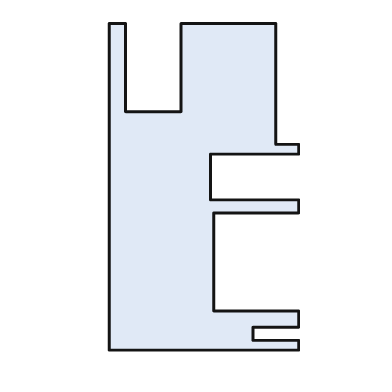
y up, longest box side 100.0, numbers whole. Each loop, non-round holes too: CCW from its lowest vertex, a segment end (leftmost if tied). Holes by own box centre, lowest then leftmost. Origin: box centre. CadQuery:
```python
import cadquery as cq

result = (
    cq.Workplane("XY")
    .moveTo(-29.0, -50.0)
    .lineTo(29.0, -50.0)
    .lineTo(29.0, -47.0)
    .lineTo(15.0, -47.0)
    .lineTo(15.0, -43.0)
    .lineTo(29.0, -43.0)
    .lineTo(29.0, -38.0)
    .lineTo(3.0, -38.0)
    .lineTo(3.0, -8.0)
    .lineTo(29.0, -8.0)
    .lineTo(29.0, -4.0)
    .lineTo(2.0, -4.0)
    .lineTo(2.0, 10.0)
    .lineTo(29.0, 10.0)
    .lineTo(29.0, 13.0)
    .lineTo(22.0, 13.0)
    .lineTo(22.0, 50.0)
    .lineTo(-7.0, 50.0)
    .lineTo(-7.0, 23.0)
    .lineTo(-24.0, 23.0)
    .lineTo(-24.0, 50.0)
    .lineTo(-29.0, 50.0)
    .close()
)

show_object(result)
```